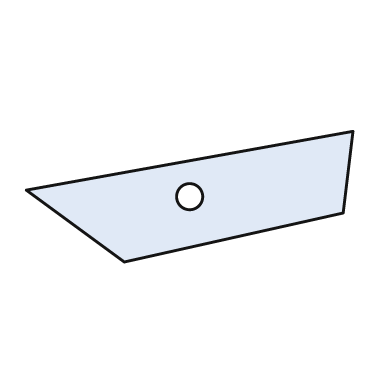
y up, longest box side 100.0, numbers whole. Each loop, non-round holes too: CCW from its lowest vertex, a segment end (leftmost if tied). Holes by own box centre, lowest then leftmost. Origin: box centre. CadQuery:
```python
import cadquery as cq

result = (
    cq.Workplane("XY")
    .moveTo(-20.0, -20.0)
    .lineTo(47.0, -5.0)
    .lineTo(50.0, 20.0)
    .lineTo(-50.0, 2.0)
    .close()
    .moveTo(0.0, 0.0)
    .circle(4.0)
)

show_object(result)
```